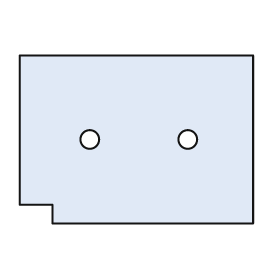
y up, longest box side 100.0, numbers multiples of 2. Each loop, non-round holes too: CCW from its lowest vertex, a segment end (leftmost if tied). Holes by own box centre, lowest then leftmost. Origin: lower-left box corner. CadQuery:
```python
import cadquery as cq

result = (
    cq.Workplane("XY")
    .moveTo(14.0, 0.0)
    .lineTo(100.0, 0.0)
    .lineTo(100.0, 72.0)
    .lineTo(0.0, 72.0)
    .lineTo(0.0, 8.0)
    .lineTo(14.0, 8.0)
    .close()
    .moveTo(30.0, 36.0)
    .circle(4.0)
    .moveTo(72.0, 36.0)
    .circle(4.0)
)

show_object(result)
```